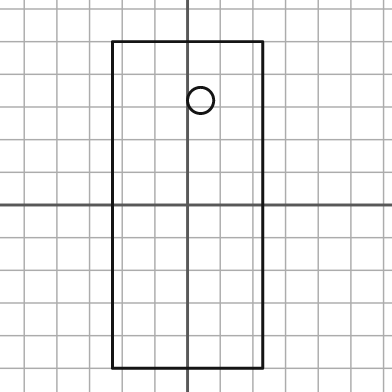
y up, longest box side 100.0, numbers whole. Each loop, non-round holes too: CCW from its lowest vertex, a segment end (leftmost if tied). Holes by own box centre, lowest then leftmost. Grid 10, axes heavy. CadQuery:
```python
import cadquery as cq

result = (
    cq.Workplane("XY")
    .moveTo(-23.0, -50.0)
    .lineTo(23.0, -50.0)
    .lineTo(23.0, 50.0)
    .lineTo(-23.0, 50.0)
    .close()
    .moveTo(4.0, 32.0)
    .circle(4.0)
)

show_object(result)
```